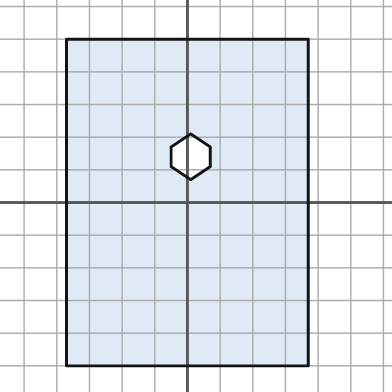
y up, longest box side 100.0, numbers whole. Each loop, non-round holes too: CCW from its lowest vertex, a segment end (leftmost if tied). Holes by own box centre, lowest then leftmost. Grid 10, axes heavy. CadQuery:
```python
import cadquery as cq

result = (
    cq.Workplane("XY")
    .moveTo(-37.0, -50.0)
    .lineTo(37.0, -50.0)
    .lineTo(37.0, 50.0)
    .lineTo(-37.0, 50.0)
    .close()
    .moveTo(1.0, 7.0)
    .lineTo(7.0, 11.0)
    .lineTo(7.0, 17.0)
    .lineTo(1.0, 21.0)
    .lineTo(-5.0, 17.0)
    .lineTo(-5.0, 11.0)
    .close()
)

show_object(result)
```